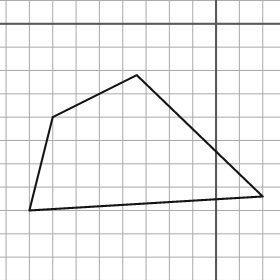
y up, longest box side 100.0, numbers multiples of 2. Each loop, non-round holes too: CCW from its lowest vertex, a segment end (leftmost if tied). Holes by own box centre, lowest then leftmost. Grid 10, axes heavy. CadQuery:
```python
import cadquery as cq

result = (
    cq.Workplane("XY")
    .moveTo(-80.0, -80.0)
    .lineTo(20.0, -74.0)
    .lineTo(-34.0, -22.0)
    .lineTo(-70.0, -40.0)
    .close()
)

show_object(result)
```